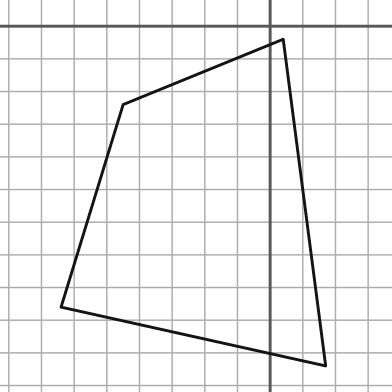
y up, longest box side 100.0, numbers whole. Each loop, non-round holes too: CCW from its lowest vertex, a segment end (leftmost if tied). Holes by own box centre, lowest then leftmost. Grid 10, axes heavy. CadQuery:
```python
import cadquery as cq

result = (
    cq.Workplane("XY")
    .moveTo(17.0, -104.0)
    .lineTo(4.0, -4.0)
    .lineTo(-45.0, -24.0)
    .lineTo(-64.0, -86.0)
    .close()
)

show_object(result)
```